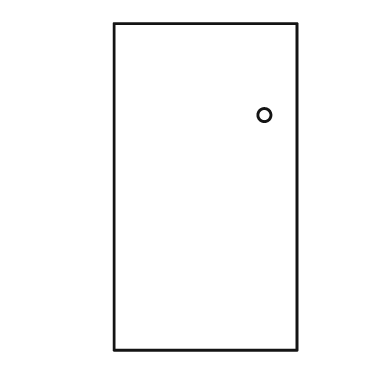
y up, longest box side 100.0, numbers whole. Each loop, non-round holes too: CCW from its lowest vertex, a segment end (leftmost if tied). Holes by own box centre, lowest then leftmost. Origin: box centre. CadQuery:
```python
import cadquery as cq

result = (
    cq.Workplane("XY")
    .moveTo(-28.0, -50.0)
    .lineTo(28.0, -50.0)
    .lineTo(28.0, 50.0)
    .lineTo(-28.0, 50.0)
    .close()
    .moveTo(18.0, 22.0)
    .circle(2.0)
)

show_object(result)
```